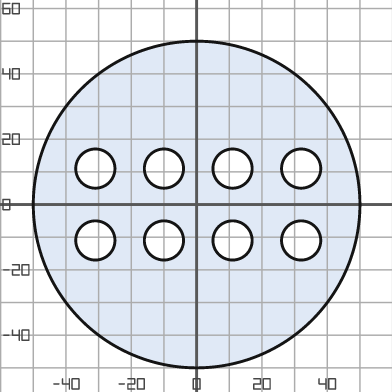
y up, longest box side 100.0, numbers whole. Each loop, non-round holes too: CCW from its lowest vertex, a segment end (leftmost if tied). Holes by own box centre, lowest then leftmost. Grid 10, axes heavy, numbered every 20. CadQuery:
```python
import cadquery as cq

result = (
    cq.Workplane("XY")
    .moveTo(0.0, 0.0)
    .circle(50.0)
    .moveTo(-31.0, -11.0)
    .circle(6.0)
    .moveTo(-10.0, -11.0)
    .circle(6.0)
    .moveTo(11.0, -11.0)
    .circle(6.0)
    .moveTo(32.0, -11.0)
    .circle(6.0)
    .moveTo(-31.0, 11.0)
    .circle(6.0)
    .moveTo(-10.0, 11.0)
    .circle(6.0)
    .moveTo(11.0, 11.0)
    .circle(6.0)
    .moveTo(32.0, 11.0)
    .circle(6.0)
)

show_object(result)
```